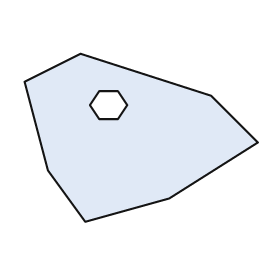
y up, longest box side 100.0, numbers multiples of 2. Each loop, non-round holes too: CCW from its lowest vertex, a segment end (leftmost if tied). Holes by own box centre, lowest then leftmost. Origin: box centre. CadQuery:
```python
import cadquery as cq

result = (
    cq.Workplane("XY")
    .moveTo(-24.0, -36.0)
    .lineTo(12.0, -26.0)
    .lineTo(50.0, -2.0)
    .lineTo(30.0, 18.0)
    .lineTo(-26.0, 36.0)
    .lineTo(-50.0, 24.0)
    .lineTo(-40.0, -14.0)
    .close()
    .moveTo(-18.0, 8.0)
    .lineTo(-10.0, 8.0)
    .lineTo(-6.0, 14.0)
    .lineTo(-10.0, 20.0)
    .lineTo(-18.0, 20.0)
    .lineTo(-22.0, 14.0)
    .close()
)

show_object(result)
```